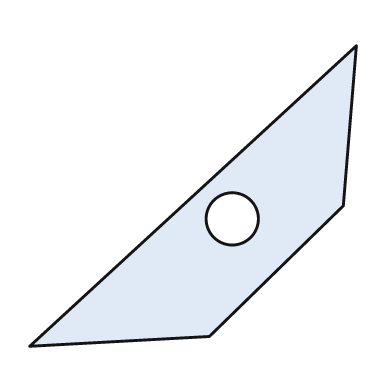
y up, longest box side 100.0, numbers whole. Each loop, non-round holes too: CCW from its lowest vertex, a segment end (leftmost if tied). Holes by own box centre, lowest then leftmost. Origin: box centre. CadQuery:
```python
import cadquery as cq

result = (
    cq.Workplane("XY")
    .moveTo(-50.0, -46.0)
    .lineTo(5.0, -43.0)
    .lineTo(46.0, -3.0)
    .lineTo(50.0, 46.0)
    .close()
    .moveTo(12.0, -7.0)
    .circle(8.0)
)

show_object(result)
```